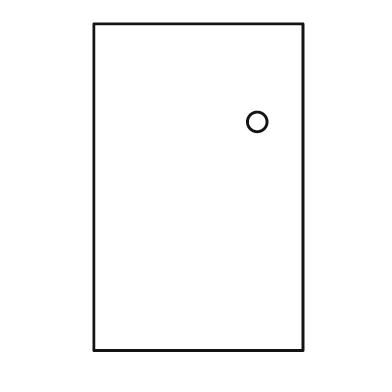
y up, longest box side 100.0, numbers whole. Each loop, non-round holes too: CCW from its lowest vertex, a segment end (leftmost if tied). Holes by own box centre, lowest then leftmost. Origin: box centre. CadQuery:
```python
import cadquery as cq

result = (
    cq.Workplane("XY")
    .moveTo(-32.0, -50.0)
    .lineTo(32.0, -50.0)
    .lineTo(32.0, 50.0)
    .lineTo(-32.0, 50.0)
    .close()
    .moveTo(18.0, 20.0)
    .circle(3.0)
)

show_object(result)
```